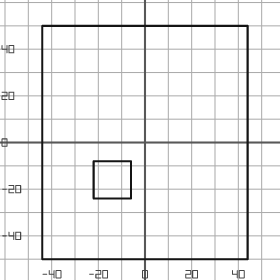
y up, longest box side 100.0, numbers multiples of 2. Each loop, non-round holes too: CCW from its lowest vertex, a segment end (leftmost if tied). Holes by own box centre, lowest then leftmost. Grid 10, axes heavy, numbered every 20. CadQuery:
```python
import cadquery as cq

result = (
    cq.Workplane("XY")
    .moveTo(-44.0, -50.0)
    .lineTo(44.0, -50.0)
    .lineTo(44.0, 50.0)
    .lineTo(-44.0, 50.0)
    .close()
    .moveTo(-22.0, -24.0)
    .lineTo(-6.0, -24.0)
    .lineTo(-6.0, -8.0)
    .lineTo(-22.0, -8.0)
    .close()
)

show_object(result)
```